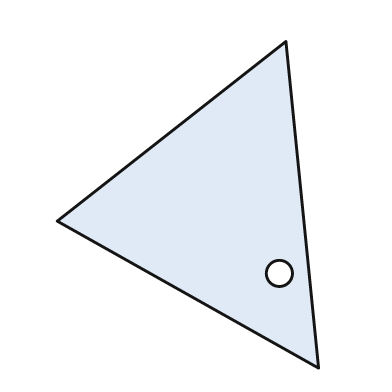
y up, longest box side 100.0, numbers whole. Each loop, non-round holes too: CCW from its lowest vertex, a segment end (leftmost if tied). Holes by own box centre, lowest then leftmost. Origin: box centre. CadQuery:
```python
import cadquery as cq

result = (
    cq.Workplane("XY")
    .moveTo(40.0, -50.0)
    .lineTo(30.0, 50.0)
    .lineTo(-40.0, -5.0)
    .close()
    .moveTo(28.0, -21.0)
    .circle(4.0)
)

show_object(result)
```